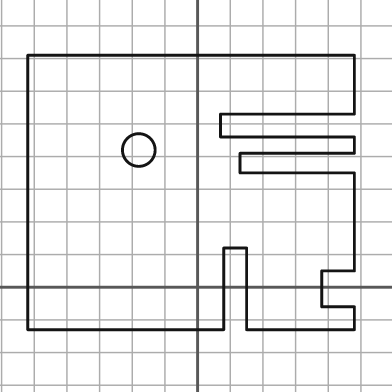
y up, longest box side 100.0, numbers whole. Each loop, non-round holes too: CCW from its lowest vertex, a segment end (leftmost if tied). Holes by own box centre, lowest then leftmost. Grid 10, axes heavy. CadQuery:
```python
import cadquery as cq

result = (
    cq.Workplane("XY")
    .moveTo(-52.0, -13.0)
    .lineTo(8.0, -13.0)
    .lineTo(8.0, 12.0)
    .lineTo(15.0, 12.0)
    .lineTo(15.0, -13.0)
    .lineTo(48.0, -13.0)
    .lineTo(48.0, -6.0)
    .lineTo(38.0, -6.0)
    .lineTo(38.0, 5.0)
    .lineTo(48.0, 5.0)
    .lineTo(48.0, 35.0)
    .lineTo(13.0, 35.0)
    .lineTo(13.0, 41.0)
    .lineTo(48.0, 41.0)
    .lineTo(48.0, 46.0)
    .lineTo(7.0, 46.0)
    .lineTo(7.0, 53.0)
    .lineTo(48.0, 53.0)
    .lineTo(48.0, 71.0)
    .lineTo(-52.0, 71.0)
    .close()
    .moveTo(-18.0, 42.0)
    .circle(5.0)
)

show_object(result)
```